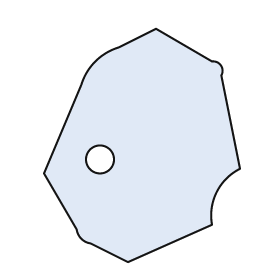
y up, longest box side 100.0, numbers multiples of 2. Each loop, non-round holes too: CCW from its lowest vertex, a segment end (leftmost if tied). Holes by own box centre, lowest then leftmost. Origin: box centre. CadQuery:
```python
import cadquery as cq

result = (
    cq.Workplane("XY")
    .moveTo(-6.0, -50.0)
    .lineTo(30.0, -34.0)
    .threePointArc((32.0, -20.0), (42.0, -10.0))
    .lineTo(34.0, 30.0)
    .threePointArc((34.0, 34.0), (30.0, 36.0))
    .lineTo(6.0, 50.0)
    .lineTo(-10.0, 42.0)
    .threePointArc((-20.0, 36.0), (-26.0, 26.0))
    .lineTo(-42.0, -12.0)
    .lineTo(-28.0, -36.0)
    .threePointArc((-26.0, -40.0), (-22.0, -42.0))
    .close()
    .moveTo(-18.0, -6.0)
    .circle(6.0)
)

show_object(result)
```